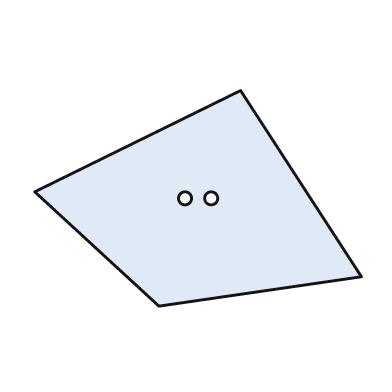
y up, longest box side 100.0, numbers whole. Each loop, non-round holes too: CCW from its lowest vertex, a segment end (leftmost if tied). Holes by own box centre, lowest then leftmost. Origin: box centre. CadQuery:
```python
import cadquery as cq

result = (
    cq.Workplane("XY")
    .moveTo(-12.0, -33.0)
    .lineTo(50.0, -24.0)
    .lineTo(13.0, 33.0)
    .lineTo(-50.0, 2.0)
    .close()
    .moveTo(-4.0, 0.0)
    .circle(2.0)
    .moveTo(4.0, 0.0)
    .circle(2.0)
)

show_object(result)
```